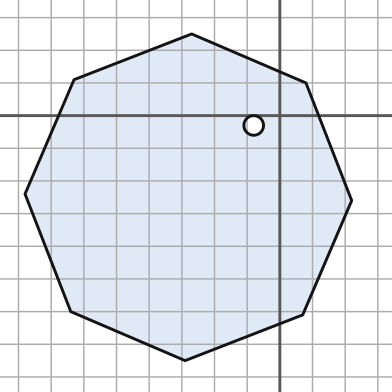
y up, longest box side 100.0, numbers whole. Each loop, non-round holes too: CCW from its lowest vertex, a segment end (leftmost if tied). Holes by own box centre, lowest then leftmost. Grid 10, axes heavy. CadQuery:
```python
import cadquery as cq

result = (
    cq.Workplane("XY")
    .moveTo(-29.0, -75.0)
    .lineTo(7.0, -61.0)
    .lineTo(22.0, -26.0)
    .lineTo(8.0, 10.0)
    .lineTo(-27.0, 25.0)
    .lineTo(-63.0, 11.0)
    .lineTo(-78.0, -24.0)
    .lineTo(-64.0, -60.0)
    .close()
    .moveTo(-8.0, -3.0)
    .circle(3.0)
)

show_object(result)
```